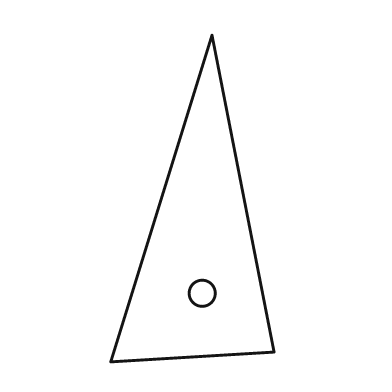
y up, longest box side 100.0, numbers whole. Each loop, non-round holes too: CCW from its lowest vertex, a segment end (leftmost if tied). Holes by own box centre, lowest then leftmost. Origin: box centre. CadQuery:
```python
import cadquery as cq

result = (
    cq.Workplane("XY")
    .moveTo(-25.0, -50.0)
    .lineTo(25.0, -47.0)
    .lineTo(6.0, 50.0)
    .close()
    .moveTo(3.0, -29.0)
    .circle(4.0)
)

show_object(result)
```